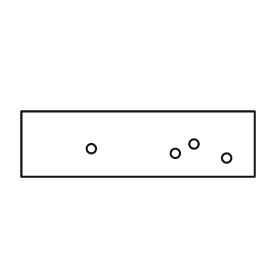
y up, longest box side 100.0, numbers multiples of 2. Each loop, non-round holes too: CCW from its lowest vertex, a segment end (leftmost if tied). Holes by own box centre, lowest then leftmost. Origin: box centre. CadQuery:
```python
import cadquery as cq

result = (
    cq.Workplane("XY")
    .moveTo(-50.0, -14.0)
    .lineTo(50.0, -14.0)
    .lineTo(50.0, 14.0)
    .lineTo(-50.0, 14.0)
    .close()
    .moveTo(38.0, -6.0)
    .circle(2.0)
    .moveTo(16.0, -4.0)
    .circle(2.0)
    .moveTo(-20.0, -2.0)
    .circle(2.0)
    .moveTo(24.0, 0.0)
    .circle(2.0)
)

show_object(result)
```